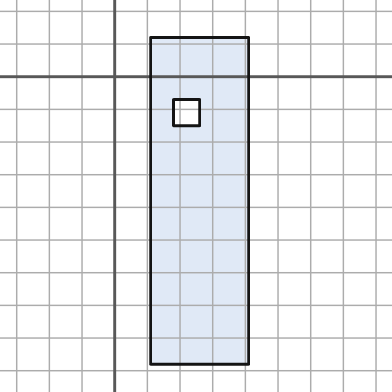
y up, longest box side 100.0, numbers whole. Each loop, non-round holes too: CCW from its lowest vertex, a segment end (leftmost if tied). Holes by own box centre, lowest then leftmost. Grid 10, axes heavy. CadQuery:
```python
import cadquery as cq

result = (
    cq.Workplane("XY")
    .moveTo(11.0, -88.0)
    .lineTo(41.0, -88.0)
    .lineTo(41.0, 12.0)
    .lineTo(11.0, 12.0)
    .close()
    .moveTo(18.0, -15.0)
    .lineTo(26.0, -15.0)
    .lineTo(26.0, -7.0)
    .lineTo(18.0, -7.0)
    .close()
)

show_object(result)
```